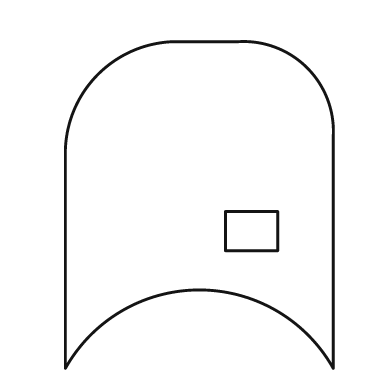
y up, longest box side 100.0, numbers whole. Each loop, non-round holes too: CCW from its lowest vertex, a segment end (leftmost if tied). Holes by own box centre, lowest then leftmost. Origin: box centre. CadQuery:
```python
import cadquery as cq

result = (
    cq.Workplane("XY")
    .moveTo(-41.0, -50.0)
    .threePointArc((0.0, -26.0), (41.0, -50.0))
    .lineTo(41.0, 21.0)
    .threePointArc((33.0, 42.0), (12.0, 50.0))
    .lineTo(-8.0, 50.0)
    .threePointArc((-31.0, 40.0), (-41.0, 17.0))
    .close()
    .moveTo(8.0, -14.0)
    .lineTo(24.0, -14.0)
    .lineTo(24.0, -2.0)
    .lineTo(8.0, -2.0)
    .close()
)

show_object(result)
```